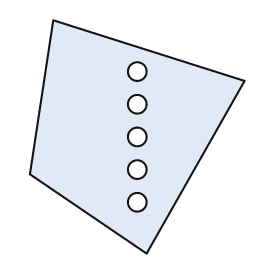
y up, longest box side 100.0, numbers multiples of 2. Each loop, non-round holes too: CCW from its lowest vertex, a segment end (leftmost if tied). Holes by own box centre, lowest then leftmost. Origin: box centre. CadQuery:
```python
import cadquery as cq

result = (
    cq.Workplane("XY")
    .moveTo(4.0, -50.0)
    .lineTo(46.0, 24.0)
    .lineTo(-36.0, 50.0)
    .lineTo(-46.0, -16.0)
    .close()
    .moveTo(0.0, -28.0)
    .circle(4.0)
    .moveTo(0.0, -14.0)
    .circle(4.0)
    .moveTo(0.0, 0.0)
    .circle(4.0)
    .moveTo(0.0, 14.0)
    .circle(4.0)
    .moveTo(0.0, 28.0)
    .circle(4.0)
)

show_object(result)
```